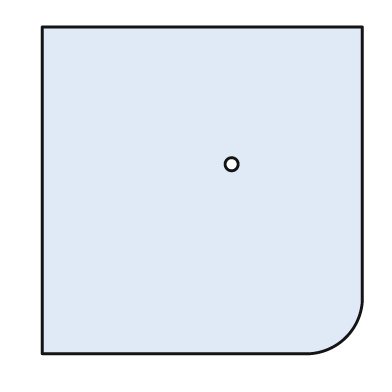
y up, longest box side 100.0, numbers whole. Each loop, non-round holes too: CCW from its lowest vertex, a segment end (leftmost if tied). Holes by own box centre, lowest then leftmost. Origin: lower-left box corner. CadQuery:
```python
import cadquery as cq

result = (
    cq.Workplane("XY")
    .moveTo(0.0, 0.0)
    .lineTo(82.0, 0.0)
    .threePointArc((93.0, 5.0), (98.0, 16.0))
    .lineTo(98.0, 100.0)
    .lineTo(0.0, 100.0)
    .close()
    .moveTo(58.0, 58.0)
    .circle(2.0)
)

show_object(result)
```